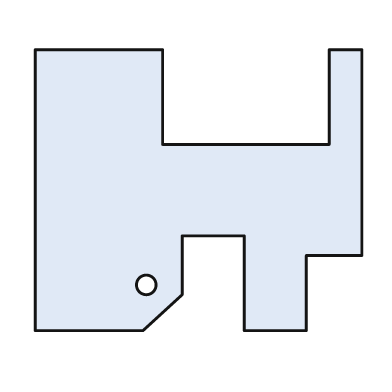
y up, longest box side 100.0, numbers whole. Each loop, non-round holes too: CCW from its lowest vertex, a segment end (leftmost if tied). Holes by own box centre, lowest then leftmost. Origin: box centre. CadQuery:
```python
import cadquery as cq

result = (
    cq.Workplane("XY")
    .moveTo(-50.0, -43.0)
    .lineTo(-17.0, -43.0)
    .lineTo(-5.0, -32.0)
    .lineTo(-5.0, -14.0)
    .lineTo(14.0, -14.0)
    .lineTo(14.0, -43.0)
    .lineTo(33.0, -43.0)
    .lineTo(33.0, -20.0)
    .lineTo(50.0, -20.0)
    .lineTo(50.0, 43.0)
    .lineTo(40.0, 43.0)
    .lineTo(40.0, 14.0)
    .lineTo(-11.0, 14.0)
    .lineTo(-11.0, 43.0)
    .lineTo(-50.0, 43.0)
    .close()
    .moveTo(-16.0, -29.0)
    .circle(3.0)
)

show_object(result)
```